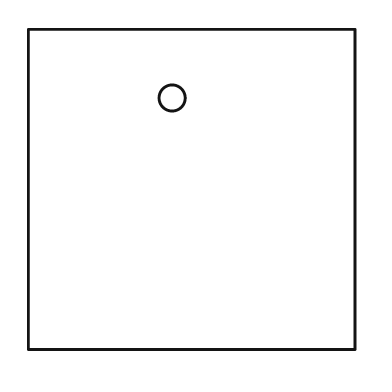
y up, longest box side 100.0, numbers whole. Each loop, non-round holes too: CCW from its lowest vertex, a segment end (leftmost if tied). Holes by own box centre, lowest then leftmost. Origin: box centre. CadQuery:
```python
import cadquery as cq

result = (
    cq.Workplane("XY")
    .moveTo(-50.0, -49.0)
    .lineTo(50.0, -49.0)
    .lineTo(50.0, 49.0)
    .lineTo(-50.0, 49.0)
    .close()
    .moveTo(-6.0, 28.0)
    .circle(4.0)
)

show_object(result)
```